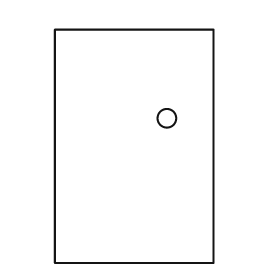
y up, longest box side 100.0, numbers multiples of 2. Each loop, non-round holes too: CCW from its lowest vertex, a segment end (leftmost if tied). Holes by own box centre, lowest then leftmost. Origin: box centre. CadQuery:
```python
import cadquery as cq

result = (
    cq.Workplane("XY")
    .moveTo(-34.0, -50.0)
    .lineTo(34.0, -50.0)
    .lineTo(34.0, 50.0)
    .lineTo(-34.0, 50.0)
    .close()
    .moveTo(14.0, 12.0)
    .circle(4.0)
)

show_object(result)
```